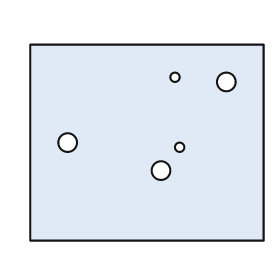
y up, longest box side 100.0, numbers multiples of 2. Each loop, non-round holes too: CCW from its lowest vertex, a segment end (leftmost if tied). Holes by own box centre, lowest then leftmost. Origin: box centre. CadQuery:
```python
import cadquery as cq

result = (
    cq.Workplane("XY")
    .moveTo(-50.0, -42.0)
    .lineTo(50.0, -42.0)
    .lineTo(50.0, 42.0)
    .lineTo(-50.0, 42.0)
    .close()
    .moveTo(6.0, -12.0)
    .circle(4.0)
    .moveTo(14.0, -2.0)
    .circle(2.0)
    .moveTo(-34.0, 0.0)
    .circle(4.0)
    .moveTo(34.0, 26.0)
    .circle(4.0)
    .moveTo(12.0, 28.0)
    .circle(2.0)
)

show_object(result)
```